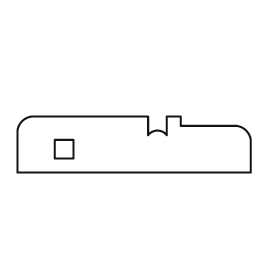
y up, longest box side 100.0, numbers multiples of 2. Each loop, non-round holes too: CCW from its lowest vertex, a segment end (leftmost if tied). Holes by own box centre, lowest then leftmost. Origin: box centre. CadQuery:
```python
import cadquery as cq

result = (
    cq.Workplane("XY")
    .moveTo(-50.0, -12.0)
    .lineTo(50.0, -12.0)
    .lineTo(50.0, 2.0)
    .threePointArc((48.0, 6.0), (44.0, 8.0))
    .lineTo(20.0, 8.0)
    .lineTo(20.0, 12.0)
    .lineTo(14.0, 12.0)
    .lineTo(14.0, 4.0)
    .threePointArc((10.0, 6.0), (6.0, 4.0))
    .lineTo(6.0, 12.0)
    .lineTo(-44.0, 12.0)
    .threePointArc((-48.0, 10.0), (-50.0, 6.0))
    .close()
    .moveTo(-34.0, -6.0)
    .lineTo(-26.0, -6.0)
    .lineTo(-26.0, 2.0)
    .lineTo(-34.0, 2.0)
    .close()
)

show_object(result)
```